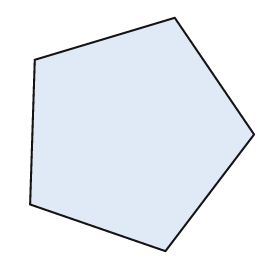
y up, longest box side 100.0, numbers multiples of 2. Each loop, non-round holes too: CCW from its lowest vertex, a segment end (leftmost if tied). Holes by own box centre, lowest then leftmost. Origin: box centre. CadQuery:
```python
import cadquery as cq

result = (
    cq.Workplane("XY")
    .moveTo(10.0, -50.0)
    .lineTo(48.0, 0.0)
    .lineTo(14.0, 50.0)
    .lineTo(-46.0, 32.0)
    .lineTo(-48.0, -30.0)
    .close()
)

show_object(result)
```